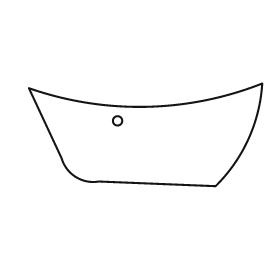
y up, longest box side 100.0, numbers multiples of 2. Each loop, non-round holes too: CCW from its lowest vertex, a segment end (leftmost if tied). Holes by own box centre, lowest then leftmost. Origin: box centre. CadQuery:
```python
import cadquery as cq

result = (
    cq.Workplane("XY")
    .moveTo(30.0, -22.0)
    .threePointArc((44.0, -2.0), (50.0, 22.0))
    .threePointArc((0.0, 12.0), (-50.0, 20.0))
    .lineTo(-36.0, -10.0)
    .threePointArc((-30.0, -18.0), (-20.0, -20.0))
    .close()
    .moveTo(-12.0, 6.0)
    .circle(2.0)
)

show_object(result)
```